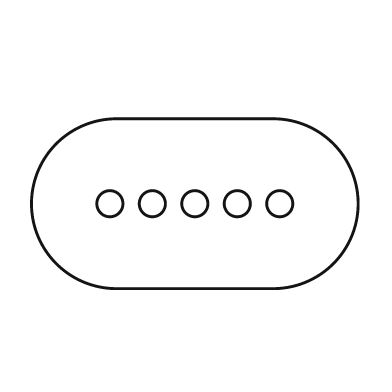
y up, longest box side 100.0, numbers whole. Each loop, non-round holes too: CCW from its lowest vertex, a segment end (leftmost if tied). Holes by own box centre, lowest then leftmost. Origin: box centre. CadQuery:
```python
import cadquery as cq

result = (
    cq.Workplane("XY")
    .moveTo(-24.0, -26.0)
    .lineTo(24.0, -26.0)
    .threePointArc((50.0, 0.0), (24.0, 26.0))
    .lineTo(-24.0, 26.0)
    .threePointArc((-50.0, 0.0), (-24.0, -26.0))
    .close()
    .moveTo(-26.0, 0.0)
    .circle(4.0)
    .moveTo(-13.0, 0.0)
    .circle(4.0)
    .moveTo(0.0, 0.0)
    .circle(4.0)
    .moveTo(13.0, 0.0)
    .circle(4.0)
    .moveTo(26.0, 0.0)
    .circle(4.0)
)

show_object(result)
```